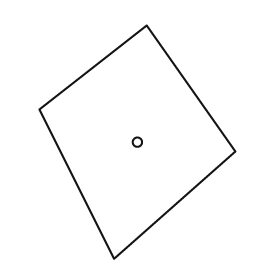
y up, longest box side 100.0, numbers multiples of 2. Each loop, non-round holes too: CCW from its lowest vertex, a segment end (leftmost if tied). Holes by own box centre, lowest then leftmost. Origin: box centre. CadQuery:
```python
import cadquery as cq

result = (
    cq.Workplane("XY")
    .moveTo(-10.0, -50.0)
    .lineTo(42.0, -4.0)
    .lineTo(4.0, 50.0)
    .lineTo(-42.0, 14.0)
    .close()
    .moveTo(0.0, 0.0)
    .circle(2.0)
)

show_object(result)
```